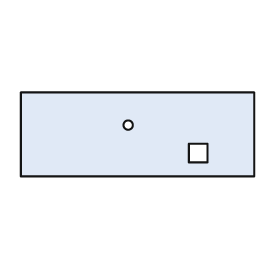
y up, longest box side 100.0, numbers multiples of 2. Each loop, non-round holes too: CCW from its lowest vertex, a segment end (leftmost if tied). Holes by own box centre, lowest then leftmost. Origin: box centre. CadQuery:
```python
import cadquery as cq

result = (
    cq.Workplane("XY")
    .moveTo(-50.0, -18.0)
    .lineTo(50.0, -18.0)
    .lineTo(50.0, 18.0)
    .lineTo(-50.0, 18.0)
    .close()
    .moveTo(22.0, -12.0)
    .lineTo(30.0, -12.0)
    .lineTo(30.0, -4.0)
    .lineTo(22.0, -4.0)
    .close()
    .moveTo(-4.0, 4.0)
    .circle(2.0)
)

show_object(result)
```